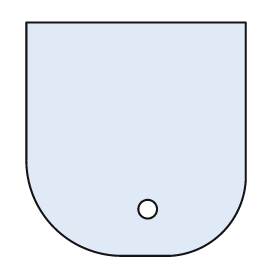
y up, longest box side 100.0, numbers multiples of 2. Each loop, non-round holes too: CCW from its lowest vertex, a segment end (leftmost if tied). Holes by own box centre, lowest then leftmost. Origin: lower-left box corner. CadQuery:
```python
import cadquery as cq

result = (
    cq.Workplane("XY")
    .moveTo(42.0, 0.0)
    .lineTo(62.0, 0.0)
    .threePointArc((84.0, 10.0), (94.0, 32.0))
    .lineTo(94.0, 100.0)
    .lineTo(0.0, 100.0)
    .lineTo(0.0, 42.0)
    .threePointArc((12.0, 12.0), (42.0, 0.0))
    .close()
    .moveTo(52.0, 20.0)
    .circle(4.0)
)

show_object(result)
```